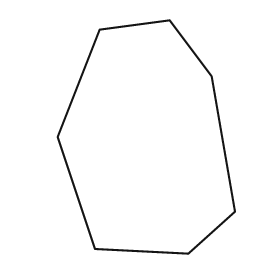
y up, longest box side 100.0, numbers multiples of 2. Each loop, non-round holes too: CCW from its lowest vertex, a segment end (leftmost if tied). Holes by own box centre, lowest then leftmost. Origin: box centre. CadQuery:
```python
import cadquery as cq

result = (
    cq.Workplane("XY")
    .moveTo(18.0, -50.0)
    .lineTo(38.0, -32.0)
    .lineTo(28.0, 26.0)
    .lineTo(10.0, 50.0)
    .lineTo(-20.0, 46.0)
    .lineTo(-38.0, 0.0)
    .lineTo(-22.0, -48.0)
    .close()
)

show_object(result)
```